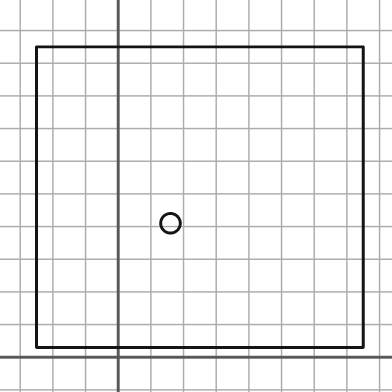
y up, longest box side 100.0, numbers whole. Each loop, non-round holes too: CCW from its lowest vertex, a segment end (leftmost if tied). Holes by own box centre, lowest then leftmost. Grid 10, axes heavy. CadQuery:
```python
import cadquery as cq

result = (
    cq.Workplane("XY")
    .moveTo(-25.0, 3.0)
    .lineTo(75.0, 3.0)
    .lineTo(75.0, 95.0)
    .lineTo(-25.0, 95.0)
    .close()
    .moveTo(16.0, 41.0)
    .circle(3.0)
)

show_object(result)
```